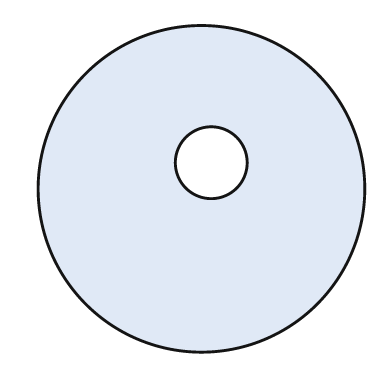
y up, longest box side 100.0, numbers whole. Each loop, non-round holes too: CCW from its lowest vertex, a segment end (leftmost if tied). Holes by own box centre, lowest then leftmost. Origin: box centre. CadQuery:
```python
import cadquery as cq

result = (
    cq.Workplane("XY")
    .moveTo(0.0, 0.0)
    .circle(50.0)
    .moveTo(3.0, 8.0)
    .circle(11.0)
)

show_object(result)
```